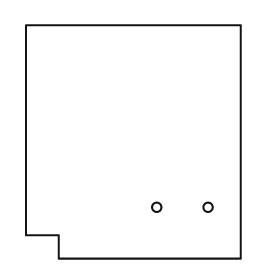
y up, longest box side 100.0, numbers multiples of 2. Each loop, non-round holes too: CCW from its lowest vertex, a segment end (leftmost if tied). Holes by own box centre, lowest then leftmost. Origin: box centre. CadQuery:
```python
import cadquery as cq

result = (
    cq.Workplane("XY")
    .moveTo(-32.0, -50.0)
    .lineTo(46.0, -50.0)
    .lineTo(46.0, 50.0)
    .lineTo(-46.0, 50.0)
    .lineTo(-46.0, -40.0)
    .lineTo(-32.0, -40.0)
    .close()
    .moveTo(10.0, -28.0)
    .circle(2.0)
    .moveTo(32.0, -28.0)
    .circle(2.0)
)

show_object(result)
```